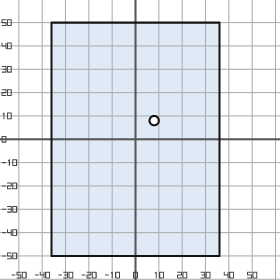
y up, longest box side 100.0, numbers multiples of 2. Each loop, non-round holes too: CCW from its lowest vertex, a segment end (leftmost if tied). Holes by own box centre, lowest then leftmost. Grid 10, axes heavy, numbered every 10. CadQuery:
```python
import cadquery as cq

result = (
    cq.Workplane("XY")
    .moveTo(-36.0, -50.0)
    .lineTo(36.0, -50.0)
    .lineTo(36.0, 50.0)
    .lineTo(-36.0, 50.0)
    .close()
    .moveTo(8.0, 8.0)
    .circle(2.0)
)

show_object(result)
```